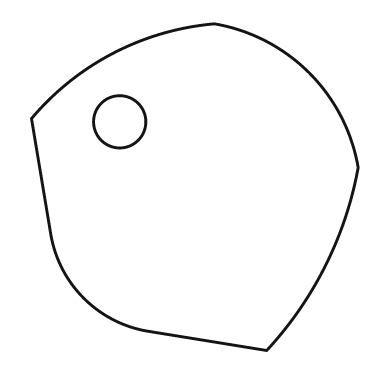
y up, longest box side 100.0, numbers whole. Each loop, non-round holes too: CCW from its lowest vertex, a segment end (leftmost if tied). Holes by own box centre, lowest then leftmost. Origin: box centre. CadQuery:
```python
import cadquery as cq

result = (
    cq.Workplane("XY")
    .moveTo(22.0, -50.0)
    .threePointArc((40.0, -24.0), (50.0, 6.0))
    .threePointArc((35.0, 35.0), (6.0, 50.0))
    .threePointArc((-25.0, 41.0), (-50.0, 21.0))
    .lineTo(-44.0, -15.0)
    .threePointArc((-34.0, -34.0), (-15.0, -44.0))
    .close()
    .moveTo(-23.0, 20.0)
    .circle(8.0)
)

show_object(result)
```